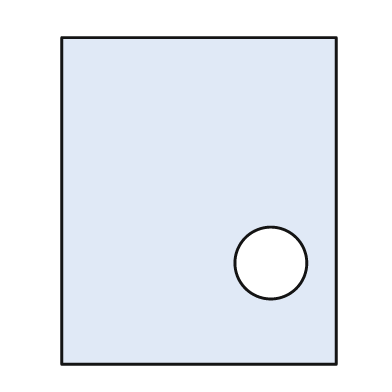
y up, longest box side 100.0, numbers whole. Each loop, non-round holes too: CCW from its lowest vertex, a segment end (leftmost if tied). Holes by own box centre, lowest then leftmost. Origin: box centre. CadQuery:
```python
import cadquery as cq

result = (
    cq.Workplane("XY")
    .moveTo(-42.0, -50.0)
    .lineTo(42.0, -50.0)
    .lineTo(42.0, 50.0)
    .lineTo(-42.0, 50.0)
    .close()
    .moveTo(22.0, -19.0)
    .circle(11.0)
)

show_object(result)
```